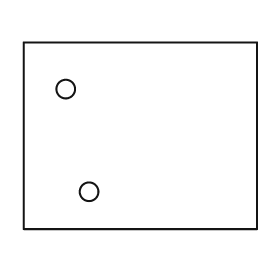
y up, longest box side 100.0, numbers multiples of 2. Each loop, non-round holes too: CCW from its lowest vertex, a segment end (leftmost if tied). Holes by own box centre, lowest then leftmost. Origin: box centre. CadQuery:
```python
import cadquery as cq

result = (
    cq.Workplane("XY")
    .moveTo(-50.0, -40.0)
    .lineTo(50.0, -40.0)
    .lineTo(50.0, 40.0)
    .lineTo(-50.0, 40.0)
    .close()
    .moveTo(-22.0, -24.0)
    .circle(4.0)
    .moveTo(-32.0, 20.0)
    .circle(4.0)
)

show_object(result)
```